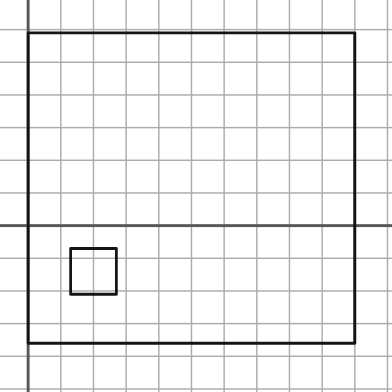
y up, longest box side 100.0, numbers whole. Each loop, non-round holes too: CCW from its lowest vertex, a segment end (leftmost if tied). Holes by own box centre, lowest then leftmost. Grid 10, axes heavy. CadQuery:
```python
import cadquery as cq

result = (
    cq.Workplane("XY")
    .moveTo(0.0, -36.0)
    .lineTo(100.0, -36.0)
    .lineTo(100.0, 59.0)
    .lineTo(0.0, 59.0)
    .close()
    .moveTo(13.0, -21.0)
    .lineTo(27.0, -21.0)
    .lineTo(27.0, -7.0)
    .lineTo(13.0, -7.0)
    .close()
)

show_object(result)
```